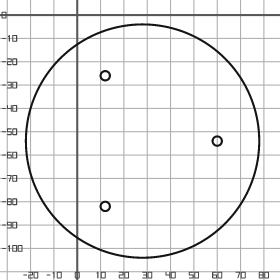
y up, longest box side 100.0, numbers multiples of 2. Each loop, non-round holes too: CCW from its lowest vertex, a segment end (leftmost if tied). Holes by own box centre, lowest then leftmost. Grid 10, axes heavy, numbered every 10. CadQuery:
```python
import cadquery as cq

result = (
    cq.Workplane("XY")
    .moveTo(28.0, -54.0)
    .circle(50.0)
    .moveTo(12.0, -82.0)
    .circle(2.0)
    .moveTo(60.0, -54.0)
    .circle(2.0)
    .moveTo(12.0, -26.0)
    .circle(2.0)
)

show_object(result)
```